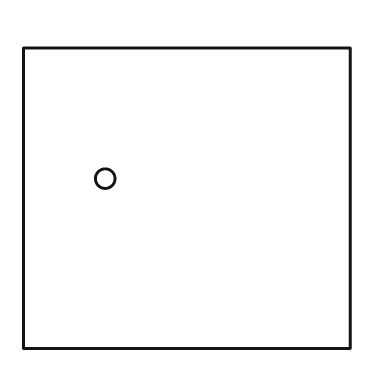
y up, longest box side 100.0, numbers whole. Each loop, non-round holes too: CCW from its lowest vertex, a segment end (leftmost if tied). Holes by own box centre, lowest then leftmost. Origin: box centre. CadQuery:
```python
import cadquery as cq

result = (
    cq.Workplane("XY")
    .moveTo(-50.0, -46.0)
    .lineTo(50.0, -46.0)
    .lineTo(50.0, 46.0)
    .lineTo(-50.0, 46.0)
    .close()
    .moveTo(-25.0, 6.0)
    .circle(3.0)
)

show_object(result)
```